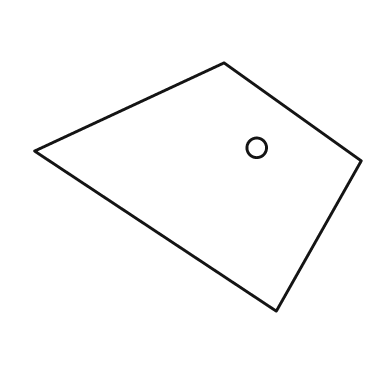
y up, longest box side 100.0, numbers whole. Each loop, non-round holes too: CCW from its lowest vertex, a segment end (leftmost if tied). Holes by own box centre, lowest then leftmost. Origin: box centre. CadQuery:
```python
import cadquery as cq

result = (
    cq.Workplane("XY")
    .moveTo(24.0, -38.0)
    .lineTo(50.0, 8.0)
    .lineTo(8.0, 38.0)
    .lineTo(-50.0, 11.0)
    .close()
    .moveTo(18.0, 12.0)
    .circle(3.0)
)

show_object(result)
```